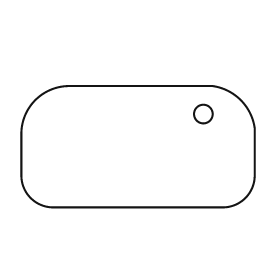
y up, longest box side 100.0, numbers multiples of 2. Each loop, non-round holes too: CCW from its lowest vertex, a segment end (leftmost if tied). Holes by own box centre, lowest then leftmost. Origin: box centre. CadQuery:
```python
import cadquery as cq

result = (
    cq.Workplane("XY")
    .moveTo(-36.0, -26.0)
    .lineTo(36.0, -26.0)
    .threePointArc((46.0, -22.0), (50.0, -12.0))
    .lineTo(50.0, 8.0)
    .threePointArc((44.0, 20.0), (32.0, 26.0))
    .lineTo(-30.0, 26.0)
    .threePointArc((-44.0, 20.0), (-50.0, 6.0))
    .lineTo(-50.0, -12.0)
    .threePointArc((-46.0, -22.0), (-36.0, -26.0))
    .close()
    .moveTo(28.0, 14.0)
    .circle(4.0)
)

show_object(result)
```